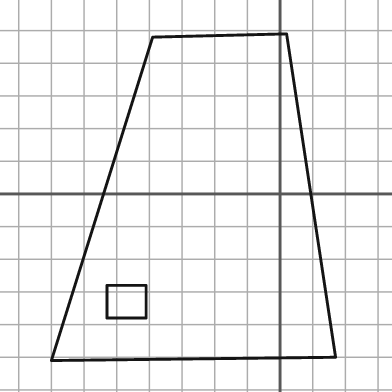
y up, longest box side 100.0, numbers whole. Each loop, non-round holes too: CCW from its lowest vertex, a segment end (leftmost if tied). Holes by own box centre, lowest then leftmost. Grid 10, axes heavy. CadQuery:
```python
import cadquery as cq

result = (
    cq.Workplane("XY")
    .moveTo(-70.0, -51.0)
    .lineTo(17.0, -50.0)
    .lineTo(2.0, 49.0)
    .lineTo(-39.0, 48.0)
    .close()
    .moveTo(-53.0, -38.0)
    .lineTo(-41.0, -38.0)
    .lineTo(-41.0, -28.0)
    .lineTo(-53.0, -28.0)
    .close()
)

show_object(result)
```